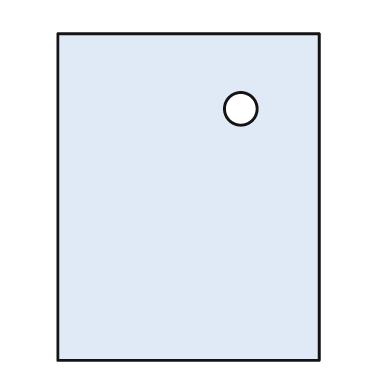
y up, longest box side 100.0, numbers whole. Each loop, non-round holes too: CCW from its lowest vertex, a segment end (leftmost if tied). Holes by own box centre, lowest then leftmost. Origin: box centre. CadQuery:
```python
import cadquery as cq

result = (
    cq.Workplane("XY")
    .moveTo(-40.0, -50.0)
    .lineTo(40.0, -50.0)
    .lineTo(40.0, 50.0)
    .lineTo(-40.0, 50.0)
    .close()
    .moveTo(16.0, 27.0)
    .circle(5.0)
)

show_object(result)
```